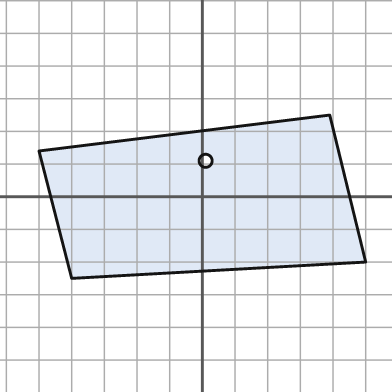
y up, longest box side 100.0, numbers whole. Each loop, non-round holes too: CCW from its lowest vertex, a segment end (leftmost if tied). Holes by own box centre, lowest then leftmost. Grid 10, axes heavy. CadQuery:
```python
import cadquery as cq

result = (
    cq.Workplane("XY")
    .moveTo(-40.0, -25.0)
    .lineTo(50.0, -20.0)
    .lineTo(39.0, 25.0)
    .lineTo(-50.0, 14.0)
    .close()
    .moveTo(1.0, 11.0)
    .circle(2.0)
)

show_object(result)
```